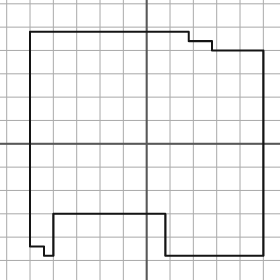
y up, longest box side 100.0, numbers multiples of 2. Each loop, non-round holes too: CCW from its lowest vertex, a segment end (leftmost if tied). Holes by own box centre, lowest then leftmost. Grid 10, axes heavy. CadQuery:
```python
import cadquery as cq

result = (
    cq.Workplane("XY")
    .moveTo(-44.0, -48.0)
    .lineTo(-40.0, -48.0)
    .lineTo(-40.0, -30.0)
    .lineTo(8.0, -30.0)
    .lineTo(8.0, -48.0)
    .lineTo(50.0, -48.0)
    .lineTo(50.0, 40.0)
    .lineTo(28.0, 40.0)
    .lineTo(28.0, 44.0)
    .lineTo(18.0, 44.0)
    .lineTo(18.0, 48.0)
    .lineTo(-50.0, 48.0)
    .lineTo(-50.0, -44.0)
    .lineTo(-44.0, -44.0)
    .close()
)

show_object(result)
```